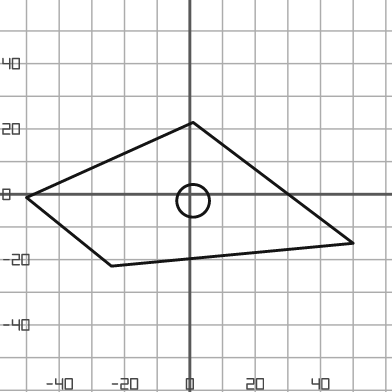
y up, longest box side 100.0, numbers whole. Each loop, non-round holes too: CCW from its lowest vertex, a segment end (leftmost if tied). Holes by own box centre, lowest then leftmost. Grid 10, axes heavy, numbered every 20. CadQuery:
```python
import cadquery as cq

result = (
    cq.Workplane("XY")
    .moveTo(-24.0, -22.0)
    .lineTo(50.0, -15.0)
    .lineTo(1.0, 22.0)
    .lineTo(-50.0, -1.0)
    .close()
    .moveTo(1.0, -2.0)
    .circle(5.0)
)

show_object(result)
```